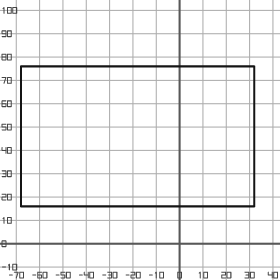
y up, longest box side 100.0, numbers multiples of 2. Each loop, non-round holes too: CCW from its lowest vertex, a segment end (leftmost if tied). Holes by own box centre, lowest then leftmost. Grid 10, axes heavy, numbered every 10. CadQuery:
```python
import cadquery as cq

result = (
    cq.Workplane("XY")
    .moveTo(-68.0, 16.0)
    .lineTo(32.0, 16.0)
    .lineTo(32.0, 76.0)
    .lineTo(-68.0, 76.0)
    .close()
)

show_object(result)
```